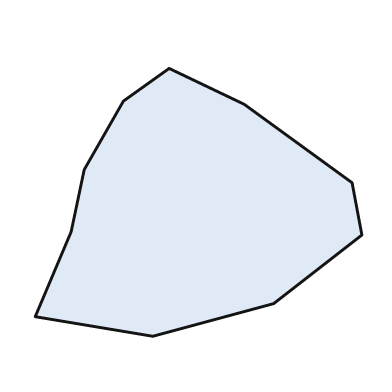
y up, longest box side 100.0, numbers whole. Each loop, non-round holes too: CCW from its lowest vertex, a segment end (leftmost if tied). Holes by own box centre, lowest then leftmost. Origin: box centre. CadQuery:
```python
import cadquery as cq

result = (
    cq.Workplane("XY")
    .moveTo(-14.0, -41.0)
    .lineTo(23.0, -31.0)
    .lineTo(50.0, -10.0)
    .lineTo(47.0, 6.0)
    .lineTo(14.0, 30.0)
    .lineTo(-9.0, 41.0)
    .lineTo(-23.0, 31.0)
    .lineTo(-35.0, 10.0)
    .lineTo(-39.0, -9.0)
    .lineTo(-50.0, -35.0)
    .close()
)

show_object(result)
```